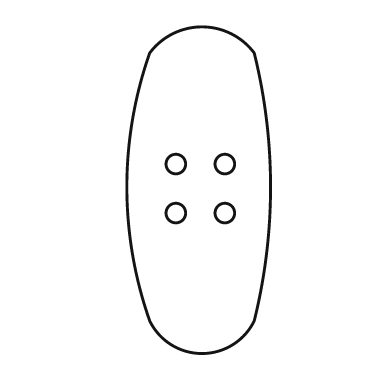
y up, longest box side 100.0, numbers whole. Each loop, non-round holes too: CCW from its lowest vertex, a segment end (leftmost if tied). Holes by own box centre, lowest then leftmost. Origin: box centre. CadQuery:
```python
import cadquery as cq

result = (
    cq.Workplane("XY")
    .moveTo(-15.0, -40.0)
    .threePointArc((1.0, -50.0), (17.0, -40.0))
    .threePointArc((22.0, 1.0), (17.0, 42.0))
    .threePointArc((1.0, 50.0), (-15.0, 42.0))
    .threePointArc((-22.0, 1.0), (-15.0, -40.0))
    .close()
    .moveTo(-7.0, -7.0)
    .circle(3.0)
    .moveTo(8.0, -7.0)
    .circle(3.0)
    .moveTo(-7.0, 8.0)
    .circle(3.0)
    .moveTo(8.0, 8.0)
    .circle(3.0)
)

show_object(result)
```